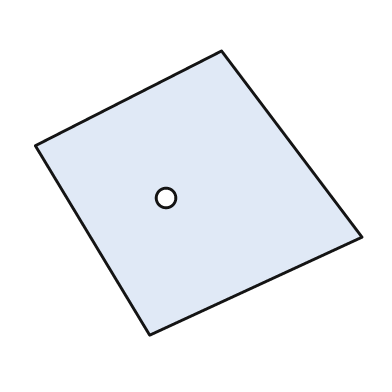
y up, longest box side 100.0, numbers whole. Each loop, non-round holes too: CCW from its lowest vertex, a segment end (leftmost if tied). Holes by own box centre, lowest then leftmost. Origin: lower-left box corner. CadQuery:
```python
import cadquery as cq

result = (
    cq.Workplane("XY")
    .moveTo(35.0, 0.0)
    .lineTo(100.0, 30.0)
    .lineTo(57.0, 87.0)
    .lineTo(0.0, 58.0)
    .close()
    .moveTo(40.0, 42.0)
    .circle(3.0)
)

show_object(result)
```